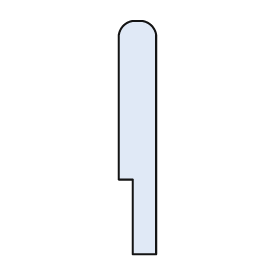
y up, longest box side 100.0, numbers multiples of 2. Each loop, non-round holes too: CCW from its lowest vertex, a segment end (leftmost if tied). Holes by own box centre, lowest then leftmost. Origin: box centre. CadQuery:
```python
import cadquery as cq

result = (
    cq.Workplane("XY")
    .moveTo(-2.0, -50.0)
    .lineTo(8.0, -50.0)
    .lineTo(8.0, 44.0)
    .threePointArc((6.0, 48.0), (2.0, 50.0))
    .lineTo(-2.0, 50.0)
    .threePointArc((-6.0, 48.0), (-8.0, 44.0))
    .lineTo(-8.0, -18.0)
    .lineTo(-2.0, -18.0)
    .close()
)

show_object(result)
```